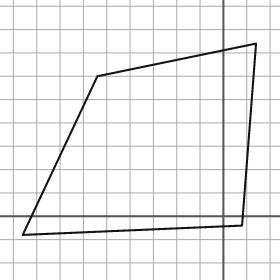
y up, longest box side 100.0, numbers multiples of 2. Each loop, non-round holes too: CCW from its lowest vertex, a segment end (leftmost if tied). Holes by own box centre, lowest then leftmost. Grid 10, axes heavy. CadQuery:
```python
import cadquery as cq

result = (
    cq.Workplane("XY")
    .moveTo(-86.0, -8.0)
    .lineTo(8.0, -4.0)
    .lineTo(14.0, 74.0)
    .lineTo(-54.0, 60.0)
    .close()
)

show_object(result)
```